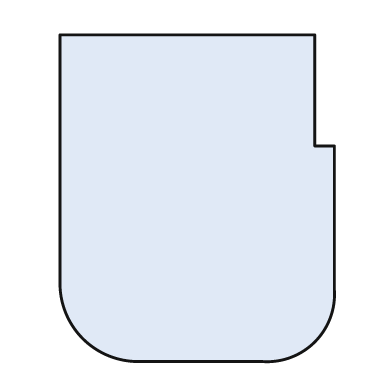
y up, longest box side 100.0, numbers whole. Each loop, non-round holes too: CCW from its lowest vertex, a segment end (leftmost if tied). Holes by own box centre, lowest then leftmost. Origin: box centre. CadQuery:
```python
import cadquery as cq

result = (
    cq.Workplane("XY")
    .moveTo(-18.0, -50.0)
    .lineTo(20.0, -50.0)
    .threePointArc((36.0, -44.0), (42.0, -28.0))
    .lineTo(42.0, 16.0)
    .lineTo(36.0, 16.0)
    .lineTo(36.0, 50.0)
    .lineTo(-42.0, 50.0)
    .lineTo(-42.0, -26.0)
    .threePointArc((-35.0, -43.0), (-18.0, -50.0))
    .close()
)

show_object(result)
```